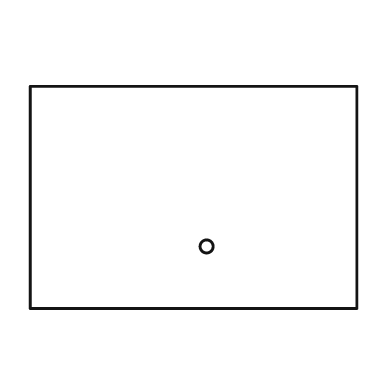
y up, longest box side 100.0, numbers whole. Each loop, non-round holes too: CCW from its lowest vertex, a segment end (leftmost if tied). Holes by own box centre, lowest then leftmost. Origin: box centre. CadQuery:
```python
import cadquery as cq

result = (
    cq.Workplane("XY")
    .moveTo(-50.0, -34.0)
    .lineTo(50.0, -34.0)
    .lineTo(50.0, 34.0)
    .lineTo(-50.0, 34.0)
    .close()
    .moveTo(4.0, -15.0)
    .circle(2.0)
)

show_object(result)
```